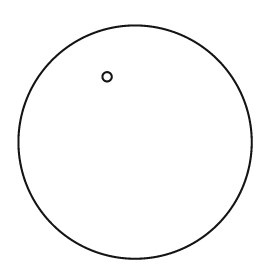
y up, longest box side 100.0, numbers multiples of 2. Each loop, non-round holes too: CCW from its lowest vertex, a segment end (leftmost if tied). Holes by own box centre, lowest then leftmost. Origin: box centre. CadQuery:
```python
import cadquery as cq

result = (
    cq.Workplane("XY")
    .moveTo(0.0, 0.0)
    .circle(50.0)
    .moveTo(-12.0, 28.0)
    .circle(2.0)
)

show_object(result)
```